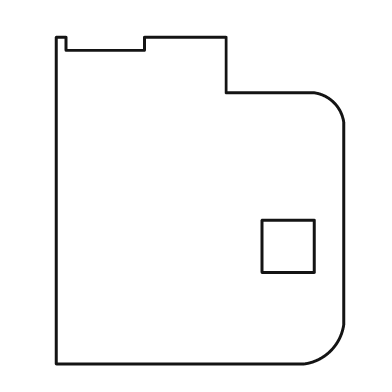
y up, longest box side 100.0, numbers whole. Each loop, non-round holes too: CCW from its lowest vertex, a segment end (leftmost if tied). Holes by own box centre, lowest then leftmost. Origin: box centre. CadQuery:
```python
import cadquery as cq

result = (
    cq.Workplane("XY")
    .moveTo(-44.0, -50.0)
    .lineTo(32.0, -50.0)
    .threePointArc((40.0, -46.0), (44.0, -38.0))
    .lineTo(44.0, 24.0)
    .threePointArc((41.0, 30.0), (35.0, 33.0))
    .lineTo(8.0, 33.0)
    .lineTo(8.0, 50.0)
    .lineTo(-17.0, 50.0)
    .lineTo(-17.0, 46.0)
    .lineTo(-41.0, 46.0)
    .lineTo(-41.0, 50.0)
    .lineTo(-44.0, 50.0)
    .close()
    .moveTo(19.0, -22.0)
    .lineTo(35.0, -22.0)
    .lineTo(35.0, -6.0)
    .lineTo(19.0, -6.0)
    .close()
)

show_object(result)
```